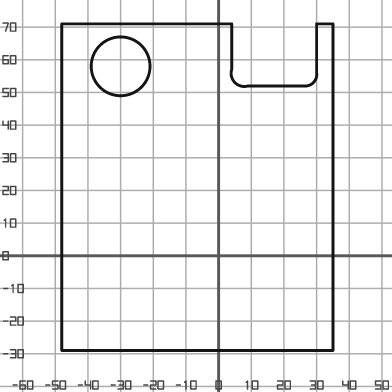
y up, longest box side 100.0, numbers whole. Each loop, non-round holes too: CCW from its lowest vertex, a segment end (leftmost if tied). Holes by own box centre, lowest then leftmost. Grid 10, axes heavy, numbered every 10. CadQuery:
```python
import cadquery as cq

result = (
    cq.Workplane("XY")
    .moveTo(-48.0, -29.0)
    .lineTo(35.0, -29.0)
    .lineTo(35.0, 71.0)
    .lineTo(30.0, 71.0)
    .lineTo(30.0, 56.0)
    .threePointArc((29.0, 53.0), (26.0, 52.0))
    .lineTo(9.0, 52.0)
    .threePointArc((5.0, 53.0), (4.0, 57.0))
    .lineTo(4.0, 71.0)
    .lineTo(-48.0, 71.0)
    .close()
    .moveTo(-30.0, 58.0)
    .circle(9.0)
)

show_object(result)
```